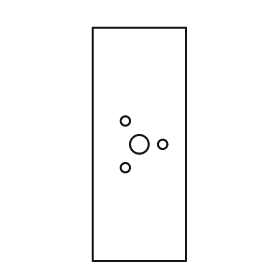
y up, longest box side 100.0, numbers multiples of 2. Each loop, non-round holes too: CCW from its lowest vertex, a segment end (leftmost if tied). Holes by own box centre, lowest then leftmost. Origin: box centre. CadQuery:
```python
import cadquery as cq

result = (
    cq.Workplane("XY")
    .moveTo(-20.0, -50.0)
    .lineTo(20.0, -50.0)
    .lineTo(20.0, 50.0)
    .lineTo(-20.0, 50.0)
    .close()
    .moveTo(-6.0, -10.0)
    .circle(2.0)
    .moveTo(0.0, 0.0)
    .circle(4.0)
    .moveTo(10.0, 0.0)
    .circle(2.0)
    .moveTo(-6.0, 10.0)
    .circle(2.0)
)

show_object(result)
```